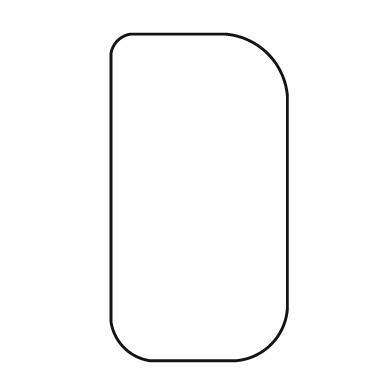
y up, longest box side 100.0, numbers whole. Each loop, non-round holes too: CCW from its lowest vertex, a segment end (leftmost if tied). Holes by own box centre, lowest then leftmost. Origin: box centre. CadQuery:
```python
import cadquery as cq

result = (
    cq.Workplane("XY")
    .moveTo(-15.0, -50.0)
    .lineTo(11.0, -50.0)
    .threePointArc((22.0, -45.0), (27.0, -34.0))
    .lineTo(27.0, 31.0)
    .threePointArc((21.0, 44.0), (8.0, 50.0))
    .lineTo(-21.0, 50.0)
    .threePointArc((-25.0, 48.0), (-27.0, 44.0))
    .lineTo(-27.0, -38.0)
    .threePointArc((-23.0, -46.0), (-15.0, -50.0))
    .close()
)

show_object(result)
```